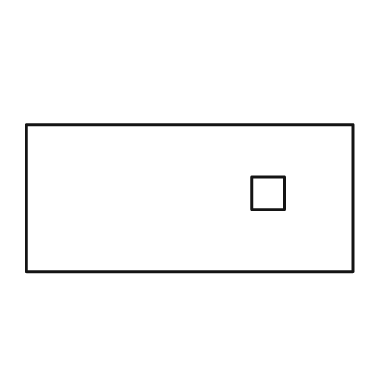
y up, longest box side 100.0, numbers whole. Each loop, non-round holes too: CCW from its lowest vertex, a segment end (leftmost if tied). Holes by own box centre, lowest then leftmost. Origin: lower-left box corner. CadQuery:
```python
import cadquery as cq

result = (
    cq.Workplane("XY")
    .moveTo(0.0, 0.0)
    .lineTo(100.0, 0.0)
    .lineTo(100.0, 45.0)
    .lineTo(0.0, 45.0)
    .close()
    .moveTo(69.0, 19.0)
    .lineTo(79.0, 19.0)
    .lineTo(79.0, 29.0)
    .lineTo(69.0, 29.0)
    .close()
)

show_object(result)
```